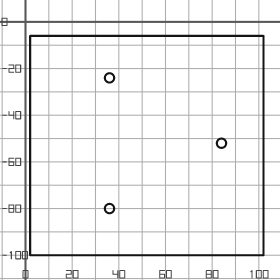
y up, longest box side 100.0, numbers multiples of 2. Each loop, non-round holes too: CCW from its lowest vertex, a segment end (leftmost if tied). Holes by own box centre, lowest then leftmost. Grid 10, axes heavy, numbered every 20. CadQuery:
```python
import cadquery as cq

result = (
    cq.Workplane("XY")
    .moveTo(2.0, -100.0)
    .lineTo(102.0, -100.0)
    .lineTo(102.0, -6.0)
    .lineTo(2.0, -6.0)
    .close()
    .moveTo(36.0, -80.0)
    .circle(2.0)
    .moveTo(84.0, -52.0)
    .circle(2.0)
    .moveTo(36.0, -24.0)
    .circle(2.0)
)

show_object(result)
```